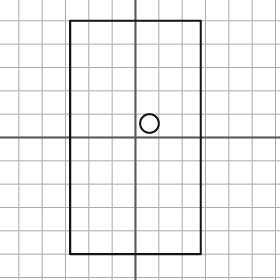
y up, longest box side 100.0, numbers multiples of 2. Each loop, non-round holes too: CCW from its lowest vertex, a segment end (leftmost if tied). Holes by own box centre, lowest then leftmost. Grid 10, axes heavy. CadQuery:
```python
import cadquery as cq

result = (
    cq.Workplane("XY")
    .moveTo(-28.0, -50.0)
    .lineTo(28.0, -50.0)
    .lineTo(28.0, 50.0)
    .lineTo(-28.0, 50.0)
    .close()
    .moveTo(6.0, 6.0)
    .circle(4.0)
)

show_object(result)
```